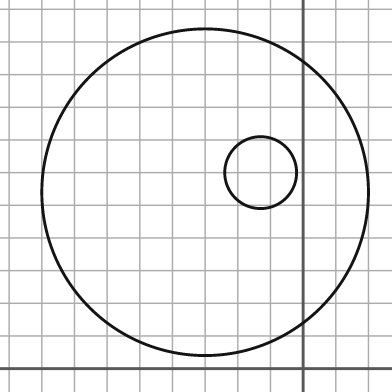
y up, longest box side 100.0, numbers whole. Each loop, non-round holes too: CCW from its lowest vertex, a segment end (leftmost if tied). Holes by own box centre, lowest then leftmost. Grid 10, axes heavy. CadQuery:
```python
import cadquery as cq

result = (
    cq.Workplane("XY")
    .moveTo(-30.0, 54.0)
    .circle(50.0)
    .moveTo(-13.0, 60.0)
    .circle(11.0)
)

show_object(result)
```